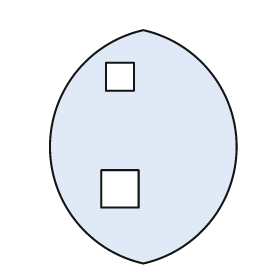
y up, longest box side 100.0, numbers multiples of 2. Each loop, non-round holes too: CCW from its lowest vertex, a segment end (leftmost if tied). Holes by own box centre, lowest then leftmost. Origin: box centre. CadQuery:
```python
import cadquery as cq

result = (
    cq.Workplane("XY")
    .moveTo(0.0, -50.0)
    .threePointArc((40.0, 0.0), (0.0, 50.0))
    .threePointArc((-40.0, 0.0), (0.0, -50.0))
    .close()
    .moveTo(-18.0, -26.0)
    .lineTo(-2.0, -26.0)
    .lineTo(-2.0, -10.0)
    .lineTo(-18.0, -10.0)
    .close()
    .moveTo(-16.0, 24.0)
    .lineTo(-4.0, 24.0)
    .lineTo(-4.0, 36.0)
    .lineTo(-16.0, 36.0)
    .close()
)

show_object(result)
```